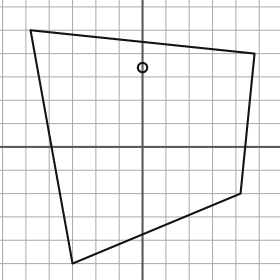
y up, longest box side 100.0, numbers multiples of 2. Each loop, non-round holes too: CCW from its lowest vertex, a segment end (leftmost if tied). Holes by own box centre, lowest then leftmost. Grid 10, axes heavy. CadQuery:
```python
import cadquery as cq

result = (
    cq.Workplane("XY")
    .moveTo(-30.0, -50.0)
    .lineTo(42.0, -20.0)
    .lineTo(48.0, 40.0)
    .lineTo(-48.0, 50.0)
    .close()
    .moveTo(0.0, 34.0)
    .circle(2.0)
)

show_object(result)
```